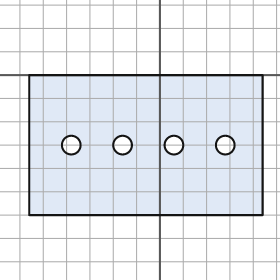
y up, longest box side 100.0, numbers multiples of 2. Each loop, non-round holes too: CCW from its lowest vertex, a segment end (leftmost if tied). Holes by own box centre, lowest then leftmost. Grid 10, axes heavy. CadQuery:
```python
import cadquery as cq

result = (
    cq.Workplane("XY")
    .moveTo(-56.0, -60.0)
    .lineTo(44.0, -60.0)
    .lineTo(44.0, 0.0)
    .lineTo(-56.0, 0.0)
    .close()
    .moveTo(-38.0, -30.0)
    .circle(4.0)
    .moveTo(-16.0, -30.0)
    .circle(4.0)
    .moveTo(6.0, -30.0)
    .circle(4.0)
    .moveTo(28.0, -30.0)
    .circle(4.0)
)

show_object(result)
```